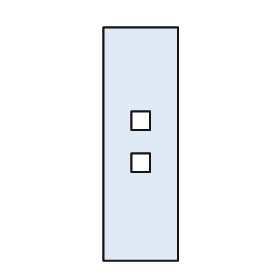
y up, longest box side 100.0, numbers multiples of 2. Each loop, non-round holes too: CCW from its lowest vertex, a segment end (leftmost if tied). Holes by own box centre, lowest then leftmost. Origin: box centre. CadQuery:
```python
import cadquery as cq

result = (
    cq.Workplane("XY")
    .moveTo(-16.0, -50.0)
    .lineTo(16.0, -50.0)
    .lineTo(16.0, 50.0)
    .lineTo(-16.0, 50.0)
    .close()
    .moveTo(-4.0, -12.0)
    .lineTo(4.0, -12.0)
    .lineTo(4.0, -4.0)
    .lineTo(-4.0, -4.0)
    .close()
    .moveTo(-4.0, 6.0)
    .lineTo(4.0, 6.0)
    .lineTo(4.0, 14.0)
    .lineTo(-4.0, 14.0)
    .close()
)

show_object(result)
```